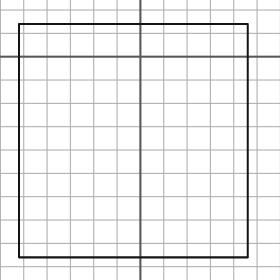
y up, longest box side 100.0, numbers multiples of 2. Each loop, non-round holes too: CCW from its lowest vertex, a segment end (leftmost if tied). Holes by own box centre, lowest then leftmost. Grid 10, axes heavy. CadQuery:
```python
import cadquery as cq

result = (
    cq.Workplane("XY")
    .moveTo(-52.0, -86.0)
    .lineTo(46.0, -86.0)
    .lineTo(46.0, 14.0)
    .lineTo(-52.0, 14.0)
    .close()
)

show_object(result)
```